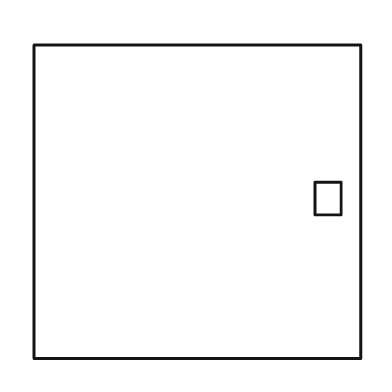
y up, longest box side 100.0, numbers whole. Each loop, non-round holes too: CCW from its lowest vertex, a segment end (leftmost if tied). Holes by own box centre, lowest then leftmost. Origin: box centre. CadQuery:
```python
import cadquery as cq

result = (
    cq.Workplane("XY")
    .moveTo(-50.0, -48.0)
    .lineTo(50.0, -48.0)
    .lineTo(50.0, 48.0)
    .lineTo(-50.0, 48.0)
    .close()
    .moveTo(36.0, -4.0)
    .lineTo(44.0, -4.0)
    .lineTo(44.0, 6.0)
    .lineTo(36.0, 6.0)
    .close()
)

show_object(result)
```